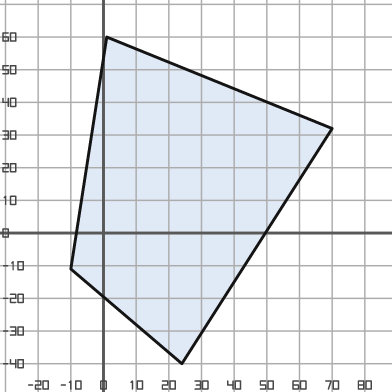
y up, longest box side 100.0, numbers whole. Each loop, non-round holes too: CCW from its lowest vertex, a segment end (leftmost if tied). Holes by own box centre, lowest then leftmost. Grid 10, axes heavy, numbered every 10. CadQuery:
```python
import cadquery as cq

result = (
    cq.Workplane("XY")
    .moveTo(24.0, -40.0)
    .lineTo(70.0, 32.0)
    .lineTo(1.0, 60.0)
    .lineTo(-10.0, -11.0)
    .close()
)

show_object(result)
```